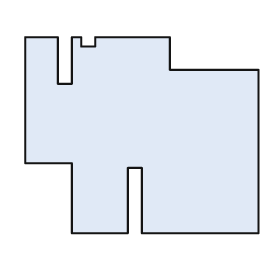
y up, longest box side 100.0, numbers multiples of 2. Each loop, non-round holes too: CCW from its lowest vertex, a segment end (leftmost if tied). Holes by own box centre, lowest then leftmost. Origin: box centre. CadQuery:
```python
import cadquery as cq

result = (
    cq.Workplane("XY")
    .moveTo(-30.0, -42.0)
    .lineTo(-6.0, -42.0)
    .lineTo(-6.0, -14.0)
    .lineTo(0.0, -14.0)
    .lineTo(0.0, -42.0)
    .lineTo(50.0, -42.0)
    .lineTo(50.0, 28.0)
    .lineTo(12.0, 28.0)
    .lineTo(12.0, 42.0)
    .lineTo(-20.0, 42.0)
    .lineTo(-20.0, 38.0)
    .lineTo(-26.0, 38.0)
    .lineTo(-26.0, 42.0)
    .lineTo(-30.0, 42.0)
    .lineTo(-30.0, 22.0)
    .lineTo(-36.0, 22.0)
    .lineTo(-36.0, 42.0)
    .lineTo(-50.0, 42.0)
    .lineTo(-50.0, -12.0)
    .lineTo(-30.0, -12.0)
    .close()
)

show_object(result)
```